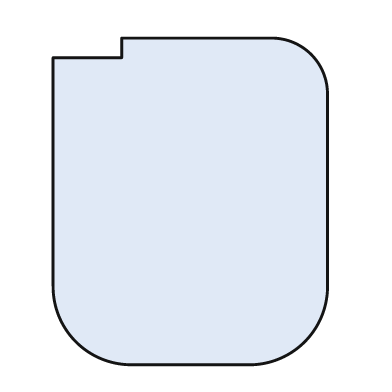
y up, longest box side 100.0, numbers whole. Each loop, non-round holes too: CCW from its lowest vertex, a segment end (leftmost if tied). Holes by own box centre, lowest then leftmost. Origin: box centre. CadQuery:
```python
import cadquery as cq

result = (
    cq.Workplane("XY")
    .moveTo(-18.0, -50.0)
    .lineTo(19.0, -50.0)
    .threePointArc((35.0, -43.0), (42.0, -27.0))
    .lineTo(42.0, 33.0)
    .threePointArc((37.0, 45.0), (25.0, 50.0))
    .lineTo(-21.0, 50.0)
    .lineTo(-21.0, 44.0)
    .lineTo(-42.0, 44.0)
    .lineTo(-42.0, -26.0)
    .threePointArc((-35.0, -43.0), (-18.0, -50.0))
    .close()
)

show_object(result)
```